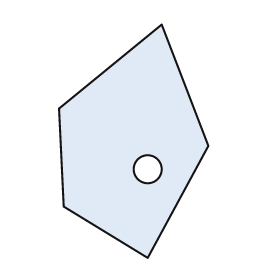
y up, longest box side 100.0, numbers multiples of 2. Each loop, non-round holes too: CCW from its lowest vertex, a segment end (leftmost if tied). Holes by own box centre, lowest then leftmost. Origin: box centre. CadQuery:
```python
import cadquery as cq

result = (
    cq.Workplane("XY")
    .moveTo(6.0, -50.0)
    .lineTo(32.0, -2.0)
    .lineTo(12.0, 50.0)
    .lineTo(-32.0, 14.0)
    .lineTo(-30.0, -28.0)
    .close()
    .moveTo(6.0, -12.0)
    .circle(6.0)
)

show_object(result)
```